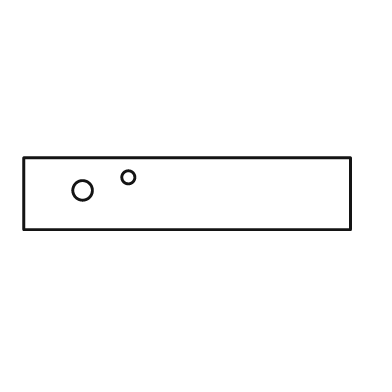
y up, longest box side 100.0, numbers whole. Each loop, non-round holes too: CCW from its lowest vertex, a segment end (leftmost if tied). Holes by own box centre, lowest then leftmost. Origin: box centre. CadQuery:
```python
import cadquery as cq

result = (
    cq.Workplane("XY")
    .moveTo(-50.0, -11.0)
    .lineTo(50.0, -11.0)
    .lineTo(50.0, 11.0)
    .lineTo(-50.0, 11.0)
    .close()
    .moveTo(-32.0, 1.0)
    .circle(3.0)
    .moveTo(-18.0, 5.0)
    .circle(2.0)
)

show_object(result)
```